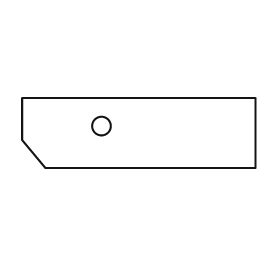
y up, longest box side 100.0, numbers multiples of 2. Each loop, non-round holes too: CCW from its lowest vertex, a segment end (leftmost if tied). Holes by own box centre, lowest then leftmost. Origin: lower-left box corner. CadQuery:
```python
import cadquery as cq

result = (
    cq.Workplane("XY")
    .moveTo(10.0, 0.0)
    .lineTo(100.0, 0.0)
    .lineTo(100.0, 30.0)
    .lineTo(0.0, 30.0)
    .lineTo(0.0, 12.0)
    .close()
    .moveTo(34.0, 18.0)
    .circle(4.0)
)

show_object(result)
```